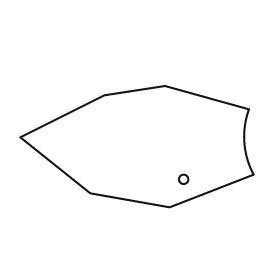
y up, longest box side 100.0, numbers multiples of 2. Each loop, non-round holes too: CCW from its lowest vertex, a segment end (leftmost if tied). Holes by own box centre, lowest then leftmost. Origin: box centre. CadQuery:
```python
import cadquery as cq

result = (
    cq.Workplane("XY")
    .moveTo(14.0, -26.0)
    .lineTo(50.0, -12.0)
    .threePointArc((46.0, 2.0), (48.0, 16.0))
    .lineTo(12.0, 26.0)
    .lineTo(-14.0, 22.0)
    .lineTo(-50.0, 4.0)
    .lineTo(-20.0, -20.0)
    .close()
    .moveTo(20.0, -14.0)
    .circle(2.0)
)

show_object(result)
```